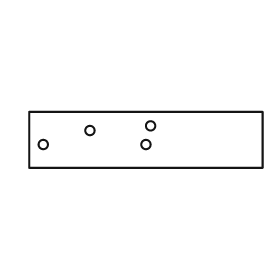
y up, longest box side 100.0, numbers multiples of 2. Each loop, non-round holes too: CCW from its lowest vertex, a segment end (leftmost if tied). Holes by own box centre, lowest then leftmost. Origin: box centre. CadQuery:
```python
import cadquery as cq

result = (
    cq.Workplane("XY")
    .moveTo(-50.0, -12.0)
    .lineTo(50.0, -12.0)
    .lineTo(50.0, 12.0)
    .lineTo(-50.0, 12.0)
    .close()
    .moveTo(-44.0, -2.0)
    .circle(2.0)
    .moveTo(0.0, -2.0)
    .circle(2.0)
    .moveTo(-24.0, 4.0)
    .circle(2.0)
    .moveTo(2.0, 6.0)
    .circle(2.0)
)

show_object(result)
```